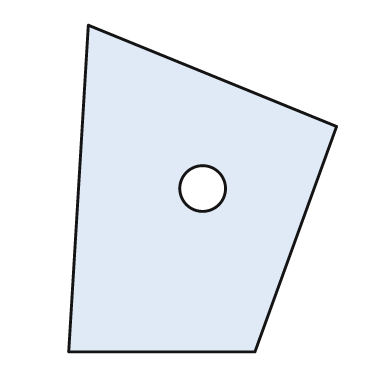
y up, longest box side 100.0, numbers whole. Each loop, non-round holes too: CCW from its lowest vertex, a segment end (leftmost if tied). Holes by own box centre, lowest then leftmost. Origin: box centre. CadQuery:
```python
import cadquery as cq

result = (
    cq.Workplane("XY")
    .moveTo(-41.0, -50.0)
    .lineTo(16.0, -50.0)
    .lineTo(41.0, 19.0)
    .lineTo(-35.0, 50.0)
    .close()
    .moveTo(0.0, 0.0)
    .circle(7.0)
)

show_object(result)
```